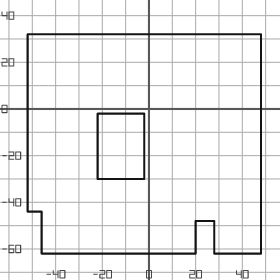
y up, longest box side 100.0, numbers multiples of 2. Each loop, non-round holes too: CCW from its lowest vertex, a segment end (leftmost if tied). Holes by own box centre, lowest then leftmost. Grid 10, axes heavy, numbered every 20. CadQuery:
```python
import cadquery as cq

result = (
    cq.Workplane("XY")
    .moveTo(-46.0, -62.0)
    .lineTo(20.0, -62.0)
    .lineTo(20.0, -48.0)
    .lineTo(28.0, -48.0)
    .lineTo(28.0, -62.0)
    .lineTo(48.0, -62.0)
    .lineTo(48.0, 32.0)
    .lineTo(-52.0, 32.0)
    .lineTo(-52.0, -44.0)
    .lineTo(-46.0, -44.0)
    .close()
    .moveTo(-22.0, -30.0)
    .lineTo(-2.0, -30.0)
    .lineTo(-2.0, -2.0)
    .lineTo(-22.0, -2.0)
    .close()
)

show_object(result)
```